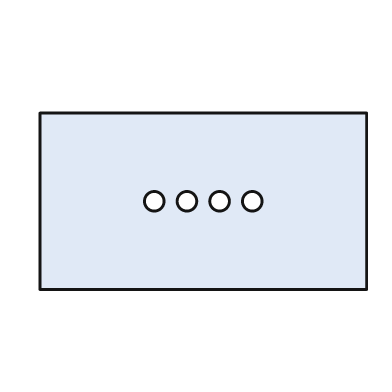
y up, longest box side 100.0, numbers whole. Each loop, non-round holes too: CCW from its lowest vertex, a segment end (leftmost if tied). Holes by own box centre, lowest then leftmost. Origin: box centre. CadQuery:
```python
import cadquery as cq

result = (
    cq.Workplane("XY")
    .moveTo(-50.0, -27.0)
    .lineTo(50.0, -27.0)
    .lineTo(50.0, 27.0)
    .lineTo(-50.0, 27.0)
    .close()
    .moveTo(-15.0, 0.0)
    .circle(3.0)
    .moveTo(-5.0, 0.0)
    .circle(3.0)
    .moveTo(5.0, 0.0)
    .circle(3.0)
    .moveTo(15.0, 0.0)
    .circle(3.0)
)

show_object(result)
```